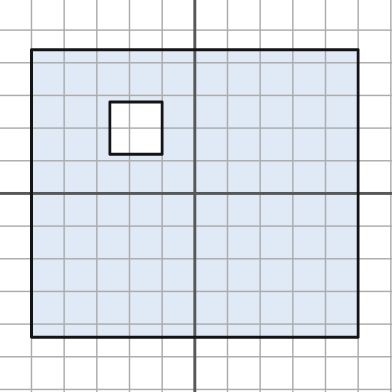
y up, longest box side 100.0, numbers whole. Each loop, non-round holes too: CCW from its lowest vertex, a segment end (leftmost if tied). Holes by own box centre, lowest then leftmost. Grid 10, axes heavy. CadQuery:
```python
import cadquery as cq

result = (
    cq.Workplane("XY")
    .moveTo(-50.0, -44.0)
    .lineTo(50.0, -44.0)
    .lineTo(50.0, 44.0)
    .lineTo(-50.0, 44.0)
    .close()
    .moveTo(-26.0, 12.0)
    .lineTo(-10.0, 12.0)
    .lineTo(-10.0, 28.0)
    .lineTo(-26.0, 28.0)
    .close()
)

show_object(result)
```